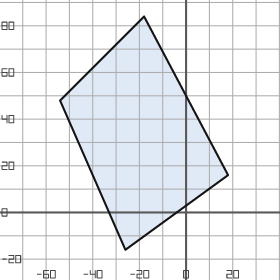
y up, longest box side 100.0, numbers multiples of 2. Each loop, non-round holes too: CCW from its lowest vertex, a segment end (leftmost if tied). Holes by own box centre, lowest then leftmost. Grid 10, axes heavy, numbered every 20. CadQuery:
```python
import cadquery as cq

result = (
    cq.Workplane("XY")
    .moveTo(-26.0, -16.0)
    .lineTo(18.0, 16.0)
    .lineTo(-18.0, 84.0)
    .lineTo(-54.0, 48.0)
    .close()
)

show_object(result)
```